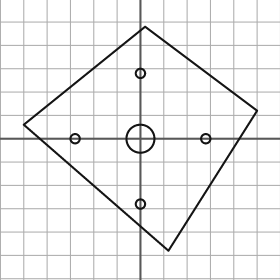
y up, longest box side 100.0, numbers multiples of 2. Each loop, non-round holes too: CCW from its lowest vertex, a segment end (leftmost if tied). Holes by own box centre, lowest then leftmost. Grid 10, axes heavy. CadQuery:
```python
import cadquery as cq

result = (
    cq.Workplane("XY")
    .moveTo(12.0, -48.0)
    .lineTo(50.0, 12.0)
    .lineTo(2.0, 48.0)
    .lineTo(-50.0, 6.0)
    .close()
    .moveTo(0.0, -28.0)
    .circle(2.0)
    .moveTo(-28.0, 0.0)
    .circle(2.0)
    .moveTo(0.0, 0.0)
    .circle(6.0)
    .moveTo(28.0, 0.0)
    .circle(2.0)
    .moveTo(0.0, 28.0)
    .circle(2.0)
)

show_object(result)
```